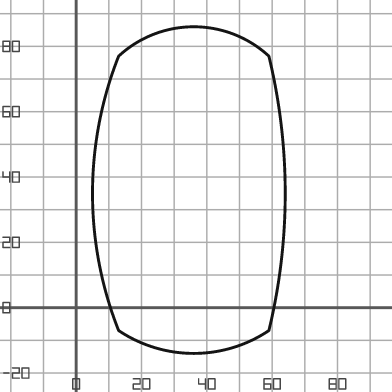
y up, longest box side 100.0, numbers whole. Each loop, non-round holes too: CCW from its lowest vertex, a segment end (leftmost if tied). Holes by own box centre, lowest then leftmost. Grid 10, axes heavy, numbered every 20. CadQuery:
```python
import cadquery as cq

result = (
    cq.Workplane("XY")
    .moveTo(13.0, -7.0)
    .threePointArc((36.0, -14.0), (59.0, -7.0))
    .threePointArc((64.0, 35.0), (59.0, 77.0))
    .threePointArc((36.0, 86.0), (13.0, 77.0))
    .threePointArc((5.0, 35.0), (13.0, -7.0))
    .close()
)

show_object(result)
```